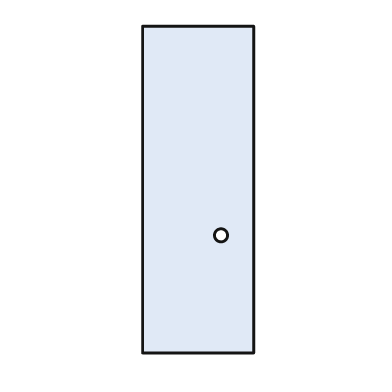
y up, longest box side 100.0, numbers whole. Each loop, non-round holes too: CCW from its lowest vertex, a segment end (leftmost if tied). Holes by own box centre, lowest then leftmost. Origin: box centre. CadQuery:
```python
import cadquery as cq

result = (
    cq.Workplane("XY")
    .moveTo(-17.0, -50.0)
    .lineTo(17.0, -50.0)
    .lineTo(17.0, 50.0)
    .lineTo(-17.0, 50.0)
    .close()
    .moveTo(7.0, -14.0)
    .circle(2.0)
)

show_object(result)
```